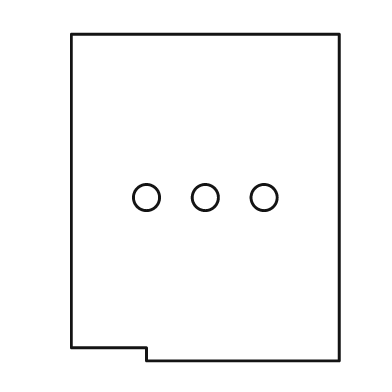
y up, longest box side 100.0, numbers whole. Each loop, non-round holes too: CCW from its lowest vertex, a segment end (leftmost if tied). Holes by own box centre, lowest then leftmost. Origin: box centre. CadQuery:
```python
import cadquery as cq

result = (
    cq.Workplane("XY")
    .moveTo(-18.0, -50.0)
    .lineTo(41.0, -50.0)
    .lineTo(41.0, 50.0)
    .lineTo(-41.0, 50.0)
    .lineTo(-41.0, -46.0)
    .lineTo(-18.0, -46.0)
    .close()
    .moveTo(-18.0, 0.0)
    .circle(4.0)
    .moveTo(0.0, 0.0)
    .circle(4.0)
    .moveTo(18.0, 0.0)
    .circle(4.0)
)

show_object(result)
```